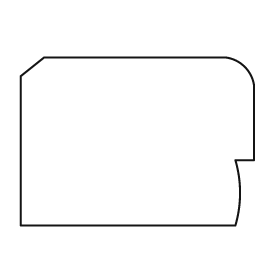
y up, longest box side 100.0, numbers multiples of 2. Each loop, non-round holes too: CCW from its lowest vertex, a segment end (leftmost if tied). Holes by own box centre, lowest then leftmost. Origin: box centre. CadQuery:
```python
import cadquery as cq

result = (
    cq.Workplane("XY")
    .moveTo(-50.0, -36.0)
    .lineTo(42.0, -36.0)
    .threePointArc((44.0, -22.0), (42.0, -8.0))
    .lineTo(50.0, -8.0)
    .lineTo(50.0, 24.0)
    .threePointArc((46.0, 32.0), (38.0, 36.0))
    .lineTo(-40.0, 36.0)
    .lineTo(-50.0, 28.0)
    .close()
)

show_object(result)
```